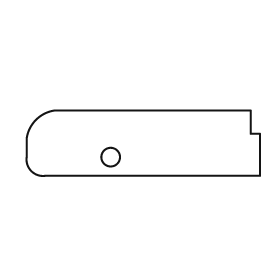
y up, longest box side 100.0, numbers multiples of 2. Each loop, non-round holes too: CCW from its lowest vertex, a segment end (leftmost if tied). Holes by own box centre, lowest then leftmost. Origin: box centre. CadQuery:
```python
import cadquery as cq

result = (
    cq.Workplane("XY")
    .moveTo(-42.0, -14.0)
    .lineTo(50.0, -14.0)
    .lineTo(50.0, 4.0)
    .lineTo(46.0, 4.0)
    .lineTo(46.0, 14.0)
    .lineTo(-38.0, 14.0)
    .threePointArc((-46.0, 10.0), (-50.0, 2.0))
    .lineTo(-50.0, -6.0)
    .threePointArc((-48.0, -12.0), (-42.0, -14.0))
    .close()
    .moveTo(-14.0, -6.0)
    .circle(4.0)
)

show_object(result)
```